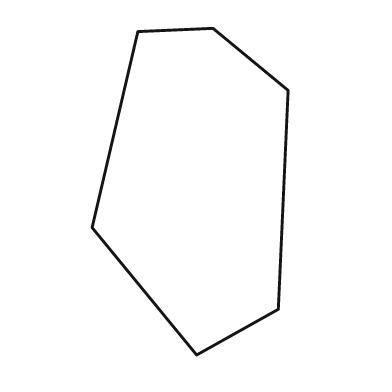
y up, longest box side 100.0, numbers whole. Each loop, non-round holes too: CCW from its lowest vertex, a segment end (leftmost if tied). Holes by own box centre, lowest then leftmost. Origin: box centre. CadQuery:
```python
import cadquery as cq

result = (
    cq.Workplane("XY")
    .moveTo(2.0, -50.0)
    .lineTo(27.0, -36.0)
    .lineTo(30.0, 31.0)
    .lineTo(7.0, 50.0)
    .lineTo(-16.0, 49.0)
    .lineTo(-30.0, -11.0)
    .close()
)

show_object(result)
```